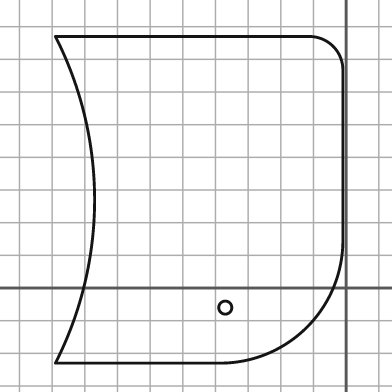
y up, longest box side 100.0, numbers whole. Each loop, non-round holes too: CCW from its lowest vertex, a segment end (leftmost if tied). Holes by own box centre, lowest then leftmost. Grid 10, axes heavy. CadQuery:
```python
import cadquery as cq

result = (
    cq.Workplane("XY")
    .moveTo(-89.0, -23.0)
    .lineTo(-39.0, -23.0)
    .threePointArc((-12.0, -12.0), (-1.0, 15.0))
    .lineTo(-1.0, 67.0)
    .threePointArc((-4.0, 74.0), (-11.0, 77.0))
    .lineTo(-89.0, 77.0)
    .threePointArc((-77.0, 27.0), (-89.0, -23.0))
    .close()
    .moveTo(-37.0, -6.0)
    .circle(2.0)
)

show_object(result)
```